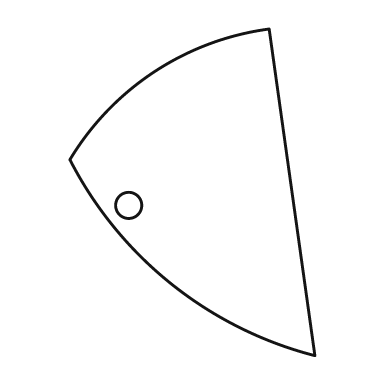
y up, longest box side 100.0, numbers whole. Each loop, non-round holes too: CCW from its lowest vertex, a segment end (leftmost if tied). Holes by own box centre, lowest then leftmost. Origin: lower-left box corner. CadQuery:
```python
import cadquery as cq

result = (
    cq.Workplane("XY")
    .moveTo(75.0, 0.0)
    .lineTo(61.0, 100.0)
    .threePointArc((26.0, 87.0), (0.0, 60.0))
    .threePointArc((31.0, 22.0), (75.0, 0.0))
    .close()
    .moveTo(18.0, 46.0)
    .circle(4.0)
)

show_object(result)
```